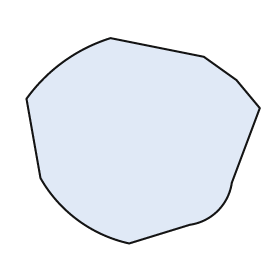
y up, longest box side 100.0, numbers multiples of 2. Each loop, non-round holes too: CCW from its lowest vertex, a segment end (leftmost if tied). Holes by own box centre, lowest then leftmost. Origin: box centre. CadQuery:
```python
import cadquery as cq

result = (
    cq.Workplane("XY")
    .moveTo(-6.0, -44.0)
    .lineTo(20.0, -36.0)
    .threePointArc((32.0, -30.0), (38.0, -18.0))
    .lineTo(50.0, 14.0)
    .lineTo(40.0, 26.0)
    .lineTo(26.0, 36.0)
    .lineTo(-14.0, 44.0)
    .threePointArc((-34.0, 34.0), (-50.0, 18.0))
    .lineTo(-44.0, -16.0)
    .threePointArc((-28.0, -34.0), (-6.0, -44.0))
    .close()
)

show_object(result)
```